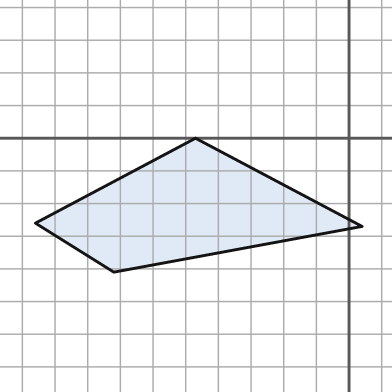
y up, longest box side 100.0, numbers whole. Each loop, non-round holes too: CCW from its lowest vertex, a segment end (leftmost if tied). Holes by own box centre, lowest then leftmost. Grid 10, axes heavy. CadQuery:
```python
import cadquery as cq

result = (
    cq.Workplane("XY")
    .moveTo(-72.0, -41.0)
    .lineTo(4.0, -27.0)
    .lineTo(-47.0, 0.0)
    .lineTo(-96.0, -26.0)
    .close()
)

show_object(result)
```